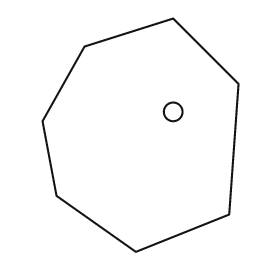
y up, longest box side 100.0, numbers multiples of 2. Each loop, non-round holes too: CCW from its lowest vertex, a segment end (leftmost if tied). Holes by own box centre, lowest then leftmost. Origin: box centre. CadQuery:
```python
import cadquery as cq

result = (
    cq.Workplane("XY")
    .moveTo(-2.0, -50.0)
    .lineTo(38.0, -34.0)
    .lineTo(42.0, 22.0)
    .lineTo(14.0, 50.0)
    .lineTo(-24.0, 38.0)
    .lineTo(-42.0, 6.0)
    .lineTo(-36.0, -26.0)
    .close()
    .moveTo(14.0, 10.0)
    .circle(4.0)
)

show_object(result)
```